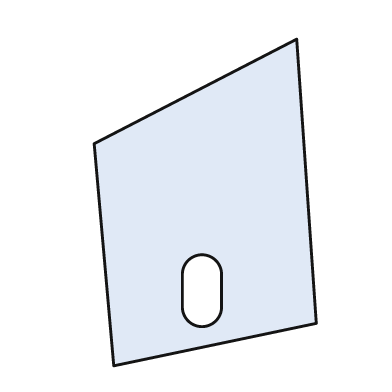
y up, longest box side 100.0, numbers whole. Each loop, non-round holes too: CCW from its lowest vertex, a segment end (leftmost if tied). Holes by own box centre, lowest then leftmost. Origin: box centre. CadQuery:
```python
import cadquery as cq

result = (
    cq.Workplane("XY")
    .moveTo(-28.0, -50.0)
    .lineTo(34.0, -37.0)
    .lineTo(28.0, 50.0)
    .lineTo(-34.0, 18.0)
    .close()
    .moveTo(-7.0, -32.0)
    .threePointArc((-1.0, -38.0), (5.0, -32.0))
    .lineTo(5.0, -22.0)
    .threePointArc((-1.0, -16.0), (-7.0, -22.0))
    .close()
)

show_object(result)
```